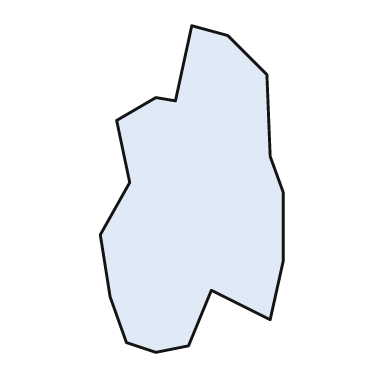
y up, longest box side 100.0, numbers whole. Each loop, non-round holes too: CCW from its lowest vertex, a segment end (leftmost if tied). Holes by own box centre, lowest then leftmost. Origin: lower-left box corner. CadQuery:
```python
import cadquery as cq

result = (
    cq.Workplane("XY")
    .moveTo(17.0, 0.0)
    .lineTo(27.0, 2.0)
    .lineTo(34.0, 19.0)
    .lineTo(52.0, 10.0)
    .lineTo(56.0, 28.0)
    .lineTo(56.0, 49.0)
    .lineTo(52.0, 60.0)
    .lineTo(51.0, 85.0)
    .lineTo(39.0, 97.0)
    .lineTo(28.0, 100.0)
    .lineTo(23.0, 77.0)
    .lineTo(17.0, 78.0)
    .lineTo(5.0, 71.0)
    .lineTo(9.0, 52.0)
    .lineTo(0.0, 36.0)
    .lineTo(3.0, 17.0)
    .lineTo(8.0, 3.0)
    .close()
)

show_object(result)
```